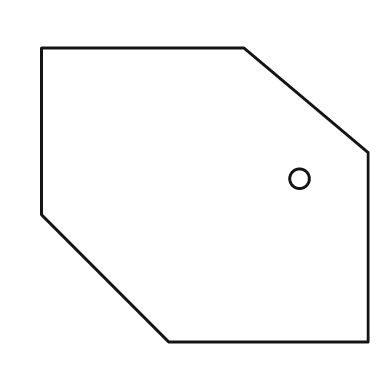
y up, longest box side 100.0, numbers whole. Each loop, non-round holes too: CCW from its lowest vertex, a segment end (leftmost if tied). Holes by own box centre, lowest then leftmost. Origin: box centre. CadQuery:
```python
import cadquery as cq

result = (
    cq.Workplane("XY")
    .moveTo(-11.0, -45.0)
    .lineTo(50.0, -45.0)
    .lineTo(50.0, 13.0)
    .lineTo(12.0, 45.0)
    .lineTo(-50.0, 45.0)
    .lineTo(-50.0, -6.0)
    .close()
    .moveTo(29.0, 5.0)
    .circle(3.0)
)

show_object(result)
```